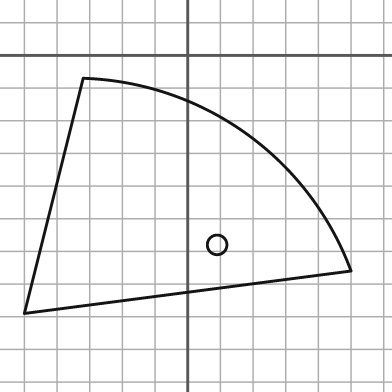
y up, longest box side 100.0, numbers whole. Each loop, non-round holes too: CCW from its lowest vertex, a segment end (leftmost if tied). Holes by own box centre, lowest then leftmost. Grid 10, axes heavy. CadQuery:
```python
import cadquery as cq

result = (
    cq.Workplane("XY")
    .moveTo(-50.0, -79.0)
    .lineTo(50.0, -66.0)
    .threePointArc((18.0, -24.0), (-32.0, -7.0))
    .close()
    .moveTo(9.0, -58.0)
    .circle(3.0)
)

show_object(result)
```